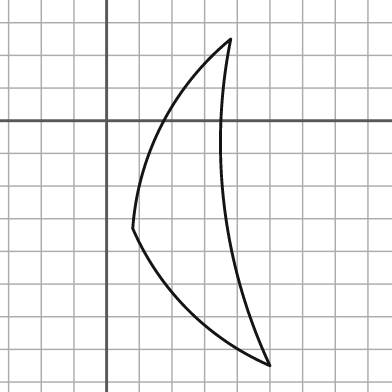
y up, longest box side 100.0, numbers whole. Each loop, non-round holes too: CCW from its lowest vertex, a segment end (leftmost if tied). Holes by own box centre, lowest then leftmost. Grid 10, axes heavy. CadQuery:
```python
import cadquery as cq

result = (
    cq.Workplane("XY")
    .moveTo(50.0, -75.0)
    .threePointArc((36.0, -26.0), (38.0, 25.0))
    .threePointArc((17.0, -1.0), (8.0, -33.0))
    .threePointArc((25.0, -58.0), (50.0, -75.0))
    .close()
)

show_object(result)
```